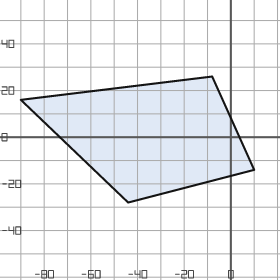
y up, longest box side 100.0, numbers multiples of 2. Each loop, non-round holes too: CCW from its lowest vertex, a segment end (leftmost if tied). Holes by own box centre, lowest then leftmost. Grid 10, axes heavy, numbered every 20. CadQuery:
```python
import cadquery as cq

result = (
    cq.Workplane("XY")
    .moveTo(-44.0, -28.0)
    .lineTo(10.0, -14.0)
    .lineTo(-8.0, 26.0)
    .lineTo(-90.0, 16.0)
    .close()
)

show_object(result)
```